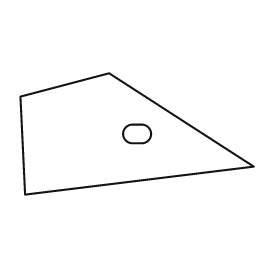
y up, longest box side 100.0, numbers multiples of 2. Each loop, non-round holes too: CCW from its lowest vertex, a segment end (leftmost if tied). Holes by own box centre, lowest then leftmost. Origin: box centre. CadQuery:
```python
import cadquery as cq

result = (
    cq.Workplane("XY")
    .moveTo(-48.0, -26.0)
    .lineTo(50.0, -14.0)
    .lineTo(-12.0, 26.0)
    .lineTo(-50.0, 16.0)
    .close()
    .moveTo(-2.0, -4.0)
    .lineTo(2.0, -4.0)
    .threePointArc((6.0, 0.0), (2.0, 4.0))
    .lineTo(-2.0, 4.0)
    .threePointArc((-6.0, 0.0), (-2.0, -4.0))
    .close()
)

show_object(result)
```